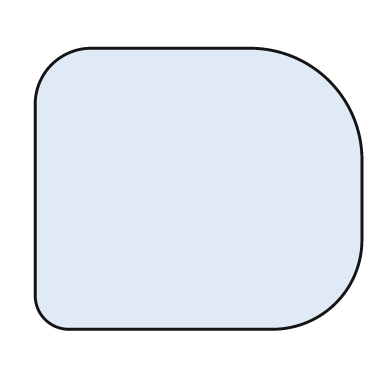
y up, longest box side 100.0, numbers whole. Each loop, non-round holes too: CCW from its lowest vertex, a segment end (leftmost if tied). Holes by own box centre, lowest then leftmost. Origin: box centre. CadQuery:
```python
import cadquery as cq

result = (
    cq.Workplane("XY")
    .moveTo(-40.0, -43.0)
    .lineTo(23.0, -43.0)
    .threePointArc((42.0, -35.0), (50.0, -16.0))
    .lineTo(50.0, 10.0)
    .threePointArc((40.0, 33.0), (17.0, 43.0))
    .lineTo(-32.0, 43.0)
    .threePointArc((-45.0, 38.0), (-50.0, 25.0))
    .lineTo(-50.0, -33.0)
    .threePointArc((-47.0, -40.0), (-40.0, -43.0))
    .close()
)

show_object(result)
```